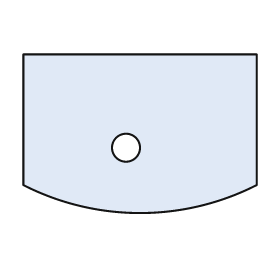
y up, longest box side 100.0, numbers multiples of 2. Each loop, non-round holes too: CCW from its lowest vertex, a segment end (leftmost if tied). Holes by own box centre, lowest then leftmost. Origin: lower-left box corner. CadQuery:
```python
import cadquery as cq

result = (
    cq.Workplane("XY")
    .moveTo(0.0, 12.0)
    .threePointArc((50.0, 0.0), (100.0, 12.0))
    .lineTo(100.0, 68.0)
    .lineTo(0.0, 68.0)
    .close()
    .moveTo(44.0, 28.0)
    .circle(6.0)
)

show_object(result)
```